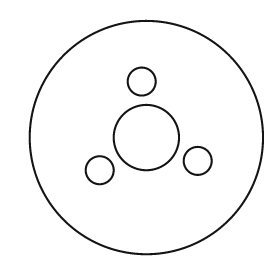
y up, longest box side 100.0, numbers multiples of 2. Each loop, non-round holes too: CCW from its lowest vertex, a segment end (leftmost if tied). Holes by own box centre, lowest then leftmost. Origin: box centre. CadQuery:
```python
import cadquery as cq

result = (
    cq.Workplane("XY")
    .moveTo(0.0, 0.0)
    .circle(50.0)
    .moveTo(-20.0, -14.0)
    .circle(6.0)
    .moveTo(22.0, -10.0)
    .circle(6.0)
    .moveTo(0.0, 0.0)
    .circle(14.0)
    .moveTo(-2.0, 24.0)
    .circle(6.0)
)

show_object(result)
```